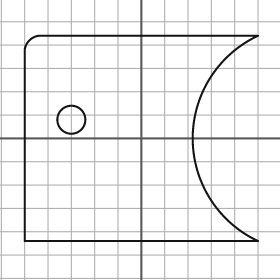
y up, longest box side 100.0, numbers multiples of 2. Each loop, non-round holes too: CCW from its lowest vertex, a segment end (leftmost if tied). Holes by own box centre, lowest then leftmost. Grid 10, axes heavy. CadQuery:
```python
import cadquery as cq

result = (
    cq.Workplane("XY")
    .moveTo(-50.0, -44.0)
    .lineTo(50.0, -44.0)
    .threePointArc((22.0, 0.0), (50.0, 44.0))
    .lineTo(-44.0, 44.0)
    .threePointArc((-48.0, 42.0), (-50.0, 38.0))
    .close()
    .moveTo(-30.0, 8.0)
    .circle(6.0)
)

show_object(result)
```